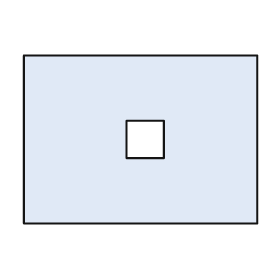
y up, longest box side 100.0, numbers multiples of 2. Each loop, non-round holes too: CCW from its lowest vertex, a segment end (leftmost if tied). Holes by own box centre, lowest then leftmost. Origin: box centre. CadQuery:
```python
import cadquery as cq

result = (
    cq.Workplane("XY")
    .moveTo(-50.0, -36.0)
    .lineTo(50.0, -36.0)
    .lineTo(50.0, 36.0)
    .lineTo(-50.0, 36.0)
    .close()
    .moveTo(-6.0, -8.0)
    .lineTo(10.0, -8.0)
    .lineTo(10.0, 8.0)
    .lineTo(-6.0, 8.0)
    .close()
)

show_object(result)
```